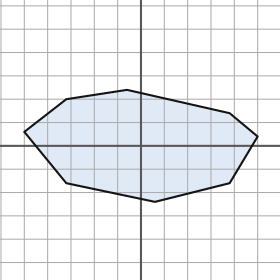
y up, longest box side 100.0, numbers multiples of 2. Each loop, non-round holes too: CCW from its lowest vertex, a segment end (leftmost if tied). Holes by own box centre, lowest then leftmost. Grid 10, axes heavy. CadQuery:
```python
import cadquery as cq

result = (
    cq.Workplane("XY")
    .moveTo(6.0, -24.0)
    .lineTo(38.0, -16.0)
    .lineTo(50.0, 4.0)
    .lineTo(38.0, 14.0)
    .lineTo(-6.0, 24.0)
    .lineTo(-32.0, 20.0)
    .lineTo(-50.0, 6.0)
    .lineTo(-32.0, -16.0)
    .close()
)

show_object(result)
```